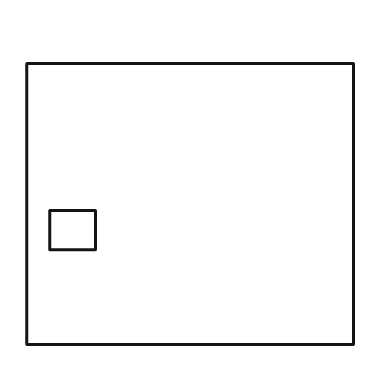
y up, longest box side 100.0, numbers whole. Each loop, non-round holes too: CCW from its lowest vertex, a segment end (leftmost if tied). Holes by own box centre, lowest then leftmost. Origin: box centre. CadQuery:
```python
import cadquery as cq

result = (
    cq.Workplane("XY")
    .moveTo(-50.0, -43.0)
    .lineTo(50.0, -43.0)
    .lineTo(50.0, 43.0)
    .lineTo(-50.0, 43.0)
    .close()
    .moveTo(-43.0, -14.0)
    .lineTo(-29.0, -14.0)
    .lineTo(-29.0, -2.0)
    .lineTo(-43.0, -2.0)
    .close()
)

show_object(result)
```